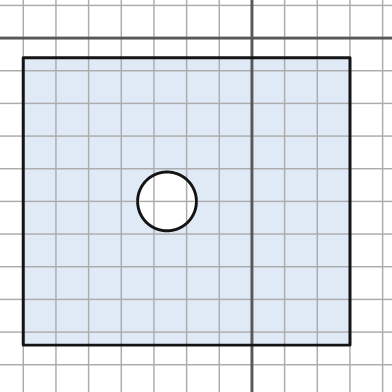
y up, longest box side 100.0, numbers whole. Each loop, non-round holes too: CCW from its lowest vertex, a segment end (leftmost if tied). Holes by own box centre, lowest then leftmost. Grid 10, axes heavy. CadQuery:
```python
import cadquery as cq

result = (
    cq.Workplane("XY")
    .moveTo(-70.0, -94.0)
    .lineTo(30.0, -94.0)
    .lineTo(30.0, -6.0)
    .lineTo(-70.0, -6.0)
    .close()
    .moveTo(-26.0, -50.0)
    .circle(9.0)
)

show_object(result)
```